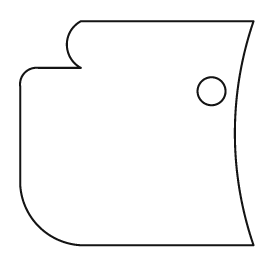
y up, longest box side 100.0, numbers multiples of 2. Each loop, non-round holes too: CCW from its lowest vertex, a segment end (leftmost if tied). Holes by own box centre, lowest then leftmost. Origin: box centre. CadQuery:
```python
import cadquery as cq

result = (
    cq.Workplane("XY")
    .moveTo(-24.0, -48.0)
    .lineTo(50.0, -48.0)
    .threePointArc((42.0, 0.0), (50.0, 48.0))
    .lineTo(-24.0, 48.0)
    .threePointArc((-30.0, 38.0), (-24.0, 28.0))
    .lineTo(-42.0, 28.0)
    .threePointArc((-48.0, 26.0), (-50.0, 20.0))
    .lineTo(-50.0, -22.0)
    .threePointArc((-42.0, -40.0), (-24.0, -48.0))
    .close()
    .moveTo(32.0, 18.0)
    .circle(6.0)
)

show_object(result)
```